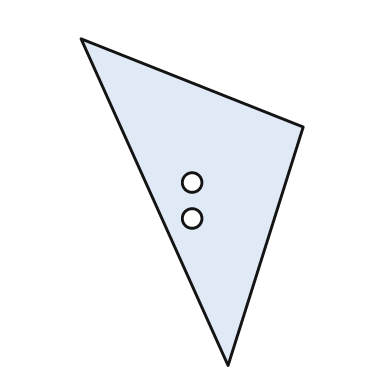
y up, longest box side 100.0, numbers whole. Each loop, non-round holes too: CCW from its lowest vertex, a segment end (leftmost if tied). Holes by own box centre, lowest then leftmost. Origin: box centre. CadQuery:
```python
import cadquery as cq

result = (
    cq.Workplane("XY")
    .moveTo(11.0, -50.0)
    .lineTo(34.0, 23.0)
    .lineTo(-34.0, 50.0)
    .close()
    .moveTo(0.0, -5.0)
    .circle(3.0)
    .moveTo(0.0, 6.0)
    .circle(3.0)
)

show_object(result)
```